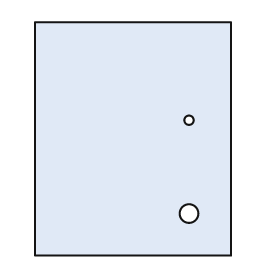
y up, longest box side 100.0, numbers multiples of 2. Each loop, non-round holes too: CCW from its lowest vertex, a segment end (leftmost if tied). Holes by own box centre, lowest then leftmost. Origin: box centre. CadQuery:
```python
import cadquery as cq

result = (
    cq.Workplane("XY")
    .moveTo(-42.0, -50.0)
    .lineTo(42.0, -50.0)
    .lineTo(42.0, 50.0)
    .lineTo(-42.0, 50.0)
    .close()
    .moveTo(24.0, -32.0)
    .circle(4.0)
    .moveTo(24.0, 8.0)
    .circle(2.0)
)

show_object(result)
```